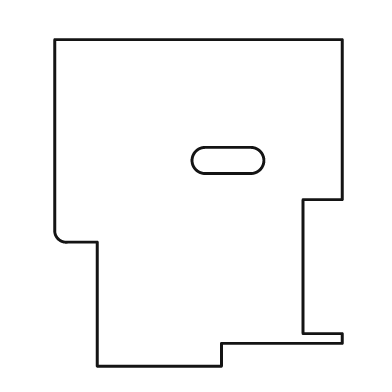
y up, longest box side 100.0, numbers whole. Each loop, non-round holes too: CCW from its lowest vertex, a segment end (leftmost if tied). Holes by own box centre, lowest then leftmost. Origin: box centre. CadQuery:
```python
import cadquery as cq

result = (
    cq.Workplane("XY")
    .moveTo(-31.0, -50.0)
    .lineTo(7.0, -50.0)
    .lineTo(7.0, -43.0)
    .lineTo(44.0, -43.0)
    .lineTo(44.0, -40.0)
    .lineTo(32.0, -40.0)
    .lineTo(32.0, 1.0)
    .lineTo(44.0, 1.0)
    .lineTo(44.0, 50.0)
    .lineTo(-44.0, 50.0)
    .lineTo(-44.0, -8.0)
    .threePointArc((-43.0, -11.0), (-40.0, -12.0))
    .lineTo(-31.0, -12.0)
    .close()
    .moveTo(2.0, 9.0)
    .lineTo(16.0, 9.0)
    .threePointArc((20.0, 13.0), (16.0, 17.0))
    .lineTo(2.0, 17.0)
    .threePointArc((-2.0, 13.0), (2.0, 9.0))
    .close()
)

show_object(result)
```